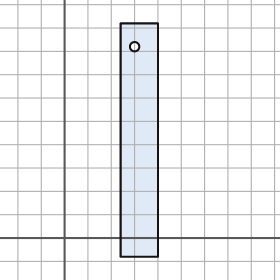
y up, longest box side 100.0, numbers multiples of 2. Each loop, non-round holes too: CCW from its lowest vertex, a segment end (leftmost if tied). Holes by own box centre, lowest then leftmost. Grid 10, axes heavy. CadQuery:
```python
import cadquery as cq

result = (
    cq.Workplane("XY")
    .moveTo(24.0, -8.0)
    .lineTo(40.0, -8.0)
    .lineTo(40.0, 92.0)
    .lineTo(24.0, 92.0)
    .close()
    .moveTo(30.0, 82.0)
    .circle(2.0)
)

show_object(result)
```